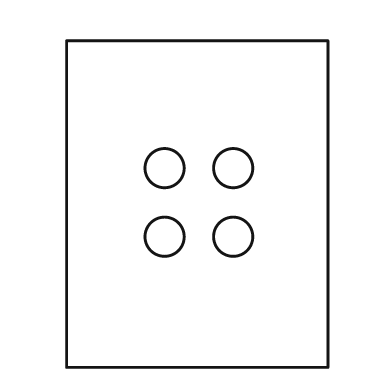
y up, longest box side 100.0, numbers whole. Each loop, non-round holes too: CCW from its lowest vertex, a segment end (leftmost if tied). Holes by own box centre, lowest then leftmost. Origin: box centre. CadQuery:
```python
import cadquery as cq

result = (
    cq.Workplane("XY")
    .moveTo(-40.0, -50.0)
    .lineTo(40.0, -50.0)
    .lineTo(40.0, 50.0)
    .lineTo(-40.0, 50.0)
    .close()
    .moveTo(-10.0, -10.0)
    .circle(6.0)
    .moveTo(11.0, -10.0)
    .circle(6.0)
    .moveTo(-10.0, 11.0)
    .circle(6.0)
    .moveTo(11.0, 11.0)
    .circle(6.0)
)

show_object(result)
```